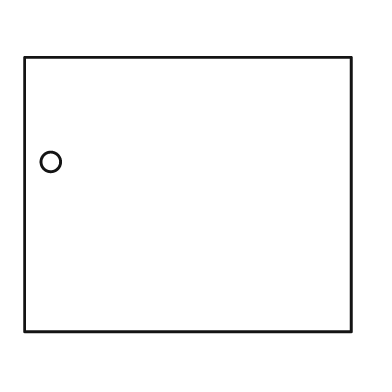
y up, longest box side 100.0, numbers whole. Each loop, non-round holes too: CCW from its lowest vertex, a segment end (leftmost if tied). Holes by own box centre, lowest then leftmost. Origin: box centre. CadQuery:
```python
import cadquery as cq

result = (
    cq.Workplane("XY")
    .moveTo(-50.0, -42.0)
    .lineTo(50.0, -42.0)
    .lineTo(50.0, 42.0)
    .lineTo(-50.0, 42.0)
    .close()
    .moveTo(-42.0, 10.0)
    .circle(3.0)
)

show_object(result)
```